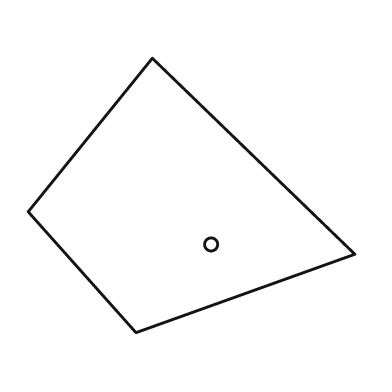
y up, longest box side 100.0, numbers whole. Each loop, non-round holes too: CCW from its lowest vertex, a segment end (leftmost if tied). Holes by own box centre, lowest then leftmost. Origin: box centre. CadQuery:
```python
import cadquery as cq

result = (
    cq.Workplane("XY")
    .moveTo(-17.0, -42.0)
    .lineTo(50.0, -18.0)
    .lineTo(-12.0, 42.0)
    .lineTo(-50.0, -5.0)
    .close()
    .moveTo(6.0, -15.0)
    .circle(2.0)
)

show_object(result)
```